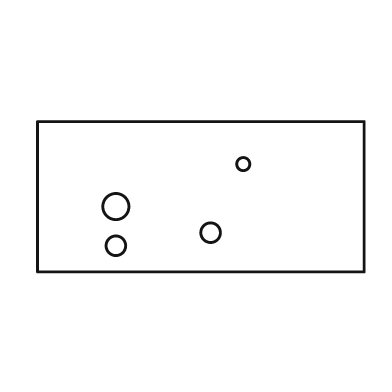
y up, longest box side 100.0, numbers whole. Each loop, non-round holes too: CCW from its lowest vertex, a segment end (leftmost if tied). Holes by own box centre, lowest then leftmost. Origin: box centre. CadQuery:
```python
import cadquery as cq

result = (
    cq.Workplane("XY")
    .moveTo(-50.0, -23.0)
    .lineTo(50.0, -23.0)
    .lineTo(50.0, 23.0)
    .lineTo(-50.0, 23.0)
    .close()
    .moveTo(-26.0, -15.0)
    .circle(3.0)
    .moveTo(3.0, -11.0)
    .circle(3.0)
    .moveTo(-26.0, -3.0)
    .circle(4.0)
    .moveTo(13.0, 10.0)
    .circle(2.0)
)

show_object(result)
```